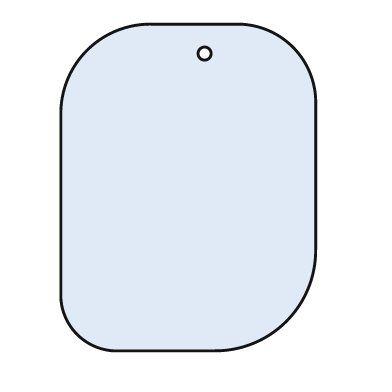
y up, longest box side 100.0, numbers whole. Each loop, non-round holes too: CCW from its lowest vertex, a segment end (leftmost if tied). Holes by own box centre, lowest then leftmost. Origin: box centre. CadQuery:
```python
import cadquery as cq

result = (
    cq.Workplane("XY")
    .moveTo(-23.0, -50.0)
    .lineTo(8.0, -50.0)
    .threePointArc((30.0, -41.0), (39.0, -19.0))
    .lineTo(39.0, 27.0)
    .threePointArc((32.0, 43.0), (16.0, 50.0))
    .lineTo(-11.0, 50.0)
    .threePointArc((-31.0, 42.0), (-39.0, 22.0))
    .lineTo(-39.0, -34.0)
    .threePointArc((-34.0, -45.0), (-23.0, -50.0))
    .close()
    .moveTo(5.0, 41.0)
    .circle(2.0)
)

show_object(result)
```